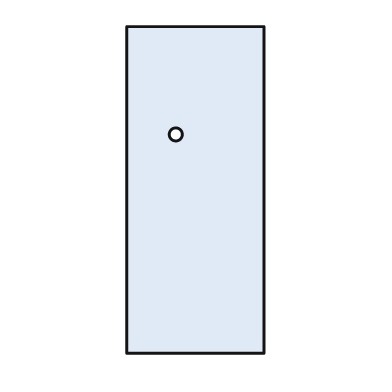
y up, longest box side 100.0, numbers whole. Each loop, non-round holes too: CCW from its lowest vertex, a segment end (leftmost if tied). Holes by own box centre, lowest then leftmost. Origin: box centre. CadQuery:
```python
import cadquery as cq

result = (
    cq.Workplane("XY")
    .moveTo(-21.0, -50.0)
    .lineTo(21.0, -50.0)
    .lineTo(21.0, 50.0)
    .lineTo(-21.0, 50.0)
    .close()
    .moveTo(-6.0, 17.0)
    .circle(2.0)
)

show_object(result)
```